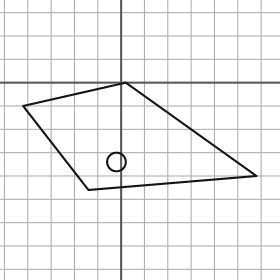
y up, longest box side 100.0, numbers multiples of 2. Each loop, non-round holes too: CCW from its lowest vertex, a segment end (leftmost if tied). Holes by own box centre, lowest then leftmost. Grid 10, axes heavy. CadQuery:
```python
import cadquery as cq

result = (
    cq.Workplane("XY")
    .moveTo(-14.0, -46.0)
    .lineTo(58.0, -40.0)
    .lineTo(2.0, 0.0)
    .lineTo(-42.0, -10.0)
    .close()
    .moveTo(-2.0, -34.0)
    .circle(4.0)
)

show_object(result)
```